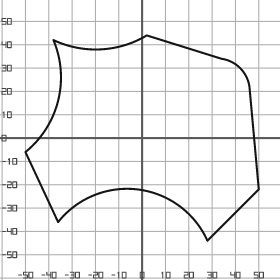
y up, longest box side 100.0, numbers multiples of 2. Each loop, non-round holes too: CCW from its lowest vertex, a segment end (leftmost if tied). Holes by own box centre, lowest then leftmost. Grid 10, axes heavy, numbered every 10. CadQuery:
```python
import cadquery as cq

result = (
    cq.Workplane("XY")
    .moveTo(28.0, -44.0)
    .lineTo(50.0, -22.0)
    .lineTo(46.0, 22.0)
    .threePointArc((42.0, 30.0), (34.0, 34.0))
    .lineTo(2.0, 44.0)
    .threePointArc((-18.0, 38.0), (-38.0, 42.0))
    .threePointArc((-36.0, 16.0), (-50.0, -6.0))
    .lineTo(-36.0, -36.0)
    .threePointArc((-2.0, -22.0), (28.0, -44.0))
    .close()
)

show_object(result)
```